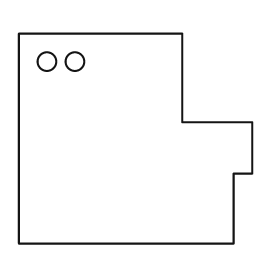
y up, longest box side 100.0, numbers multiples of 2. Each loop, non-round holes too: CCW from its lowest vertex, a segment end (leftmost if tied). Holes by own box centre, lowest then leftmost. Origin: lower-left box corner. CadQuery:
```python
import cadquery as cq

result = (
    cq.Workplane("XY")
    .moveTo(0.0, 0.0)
    .lineTo(92.0, 0.0)
    .lineTo(92.0, 30.0)
    .lineTo(100.0, 30.0)
    .lineTo(100.0, 52.0)
    .lineTo(70.0, 52.0)
    .lineTo(70.0, 90.0)
    .lineTo(0.0, 90.0)
    .close()
    .moveTo(12.0, 78.0)
    .circle(4.0)
    .moveTo(24.0, 78.0)
    .circle(4.0)
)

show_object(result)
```